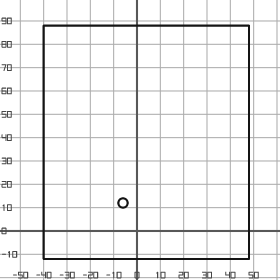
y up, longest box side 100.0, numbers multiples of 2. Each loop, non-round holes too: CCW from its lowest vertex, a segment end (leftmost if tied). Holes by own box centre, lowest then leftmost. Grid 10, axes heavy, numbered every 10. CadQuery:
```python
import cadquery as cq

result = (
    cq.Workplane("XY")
    .moveTo(-40.0, -12.0)
    .lineTo(48.0, -12.0)
    .lineTo(48.0, 88.0)
    .lineTo(-40.0, 88.0)
    .close()
    .moveTo(-6.0, 12.0)
    .circle(2.0)
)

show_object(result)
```